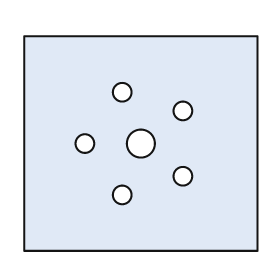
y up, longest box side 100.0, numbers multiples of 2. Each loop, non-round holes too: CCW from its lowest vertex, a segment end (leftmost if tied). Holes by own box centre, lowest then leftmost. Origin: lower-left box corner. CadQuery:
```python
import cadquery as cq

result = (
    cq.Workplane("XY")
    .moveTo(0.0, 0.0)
    .lineTo(100.0, 0.0)
    .lineTo(100.0, 92.0)
    .lineTo(0.0, 92.0)
    .close()
    .moveTo(42.0, 24.0)
    .circle(4.0)
    .moveTo(68.0, 32.0)
    .circle(4.0)
    .moveTo(26.0, 46.0)
    .circle(4.0)
    .moveTo(50.0, 46.0)
    .circle(6.0)
    .moveTo(68.0, 60.0)
    .circle(4.0)
    .moveTo(42.0, 68.0)
    .circle(4.0)
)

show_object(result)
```